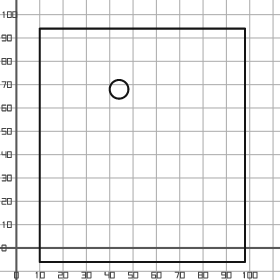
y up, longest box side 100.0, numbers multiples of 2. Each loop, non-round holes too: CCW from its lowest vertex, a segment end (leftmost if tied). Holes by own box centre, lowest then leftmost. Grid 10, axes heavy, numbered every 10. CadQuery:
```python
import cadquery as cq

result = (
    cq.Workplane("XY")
    .moveTo(10.0, -6.0)
    .lineTo(98.0, -6.0)
    .lineTo(98.0, 94.0)
    .lineTo(10.0, 94.0)
    .close()
    .moveTo(44.0, 68.0)
    .circle(4.0)
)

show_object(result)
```